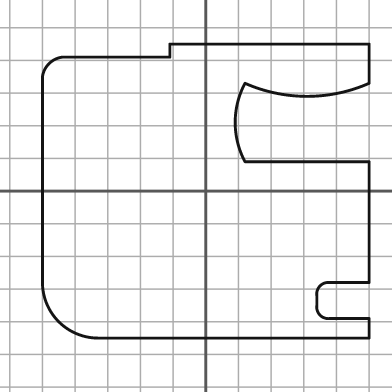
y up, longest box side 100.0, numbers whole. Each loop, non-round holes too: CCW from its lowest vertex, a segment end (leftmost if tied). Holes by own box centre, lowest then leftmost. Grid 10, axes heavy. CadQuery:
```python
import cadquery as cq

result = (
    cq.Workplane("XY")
    .moveTo(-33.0, -45.0)
    .lineTo(50.0, -45.0)
    .lineTo(50.0, -39.0)
    .lineTo(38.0, -39.0)
    .threePointArc((35.0, -38.0), (34.0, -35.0))
    .lineTo(34.0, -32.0)
    .threePointArc((35.0, -29.0), (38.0, -28.0))
    .lineTo(50.0, -28.0)
    .lineTo(50.0, 9.0)
    .lineTo(12.0, 9.0)
    .threePointArc((9.0, 21.0), (12.0, 33.0))
    .threePointArc((31.0, 29.0), (50.0, 33.0))
    .lineTo(50.0, 45.0)
    .lineTo(-11.0, 45.0)
    .lineTo(-11.0, 41.0)
    .lineTo(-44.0, 41.0)
    .threePointArc((-48.0, 39.0), (-50.0, 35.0))
    .lineTo(-50.0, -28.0)
    .threePointArc((-45.0, -40.0), (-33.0, -45.0))
    .close()
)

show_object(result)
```